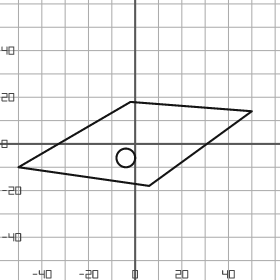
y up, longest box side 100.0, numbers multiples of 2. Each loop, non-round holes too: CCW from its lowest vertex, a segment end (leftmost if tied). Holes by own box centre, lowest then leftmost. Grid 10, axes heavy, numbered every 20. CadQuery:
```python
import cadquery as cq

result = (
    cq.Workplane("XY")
    .moveTo(6.0, -18.0)
    .lineTo(50.0, 14.0)
    .lineTo(-2.0, 18.0)
    .lineTo(-50.0, -10.0)
    .close()
    .moveTo(-4.0, -6.0)
    .circle(4.0)
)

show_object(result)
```